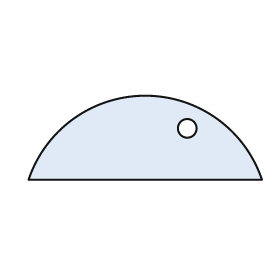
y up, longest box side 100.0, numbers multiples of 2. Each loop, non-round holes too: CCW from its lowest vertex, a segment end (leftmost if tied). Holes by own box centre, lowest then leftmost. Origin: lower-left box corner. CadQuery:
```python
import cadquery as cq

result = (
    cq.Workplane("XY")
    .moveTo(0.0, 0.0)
    .lineTo(100.0, 0.0)
    .threePointArc((50.0, 36.0), (0.0, 0.0))
    .close()
    .moveTo(68.0, 22.0)
    .circle(4.0)
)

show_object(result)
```